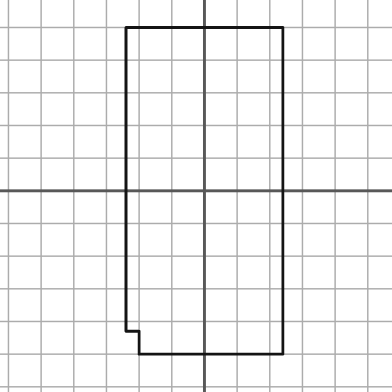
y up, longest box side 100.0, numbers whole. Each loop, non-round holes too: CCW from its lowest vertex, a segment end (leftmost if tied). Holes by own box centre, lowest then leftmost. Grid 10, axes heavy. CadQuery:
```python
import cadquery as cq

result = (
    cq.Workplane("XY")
    .moveTo(-20.0, -50.0)
    .lineTo(24.0, -50.0)
    .lineTo(24.0, 50.0)
    .lineTo(-24.0, 50.0)
    .lineTo(-24.0, -43.0)
    .lineTo(-20.0, -43.0)
    .close()
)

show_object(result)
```